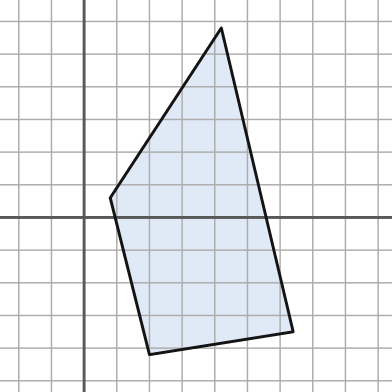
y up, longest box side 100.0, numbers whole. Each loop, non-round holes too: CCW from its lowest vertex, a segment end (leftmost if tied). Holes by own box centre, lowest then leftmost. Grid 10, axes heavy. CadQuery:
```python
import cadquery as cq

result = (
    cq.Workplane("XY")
    .moveTo(20.0, -42.0)
    .lineTo(64.0, -35.0)
    .lineTo(42.0, 58.0)
    .lineTo(8.0, 6.0)
    .close()
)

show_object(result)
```